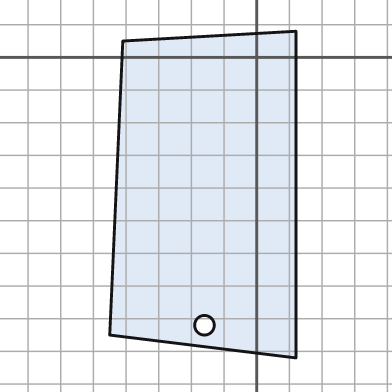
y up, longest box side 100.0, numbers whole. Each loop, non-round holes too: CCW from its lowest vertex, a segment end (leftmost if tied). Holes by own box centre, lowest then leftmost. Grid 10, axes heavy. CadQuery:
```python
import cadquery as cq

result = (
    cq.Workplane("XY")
    .moveTo(12.0, -92.0)
    .lineTo(12.0, 8.0)
    .lineTo(-41.0, 5.0)
    .lineTo(-45.0, -85.0)
    .close()
    .moveTo(-16.0, -82.0)
    .circle(3.0)
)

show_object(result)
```